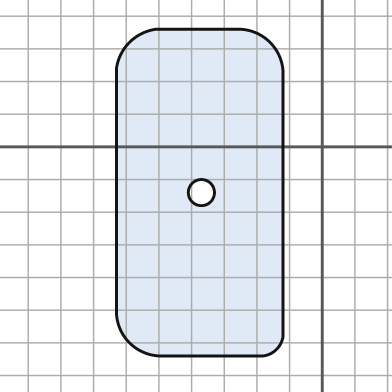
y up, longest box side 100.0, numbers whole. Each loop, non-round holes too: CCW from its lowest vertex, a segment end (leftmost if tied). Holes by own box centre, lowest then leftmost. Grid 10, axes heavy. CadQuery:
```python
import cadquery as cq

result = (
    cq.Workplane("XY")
    .moveTo(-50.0, -64.0)
    .lineTo(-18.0, -64.0)
    .threePointArc((-14.0, -62.0), (-12.0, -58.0))
    .lineTo(-12.0, 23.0)
    .threePointArc((-16.0, 32.0), (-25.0, 36.0))
    .lineTo(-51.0, 36.0)
    .threePointArc((-59.0, 32.0), (-63.0, 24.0))
    .lineTo(-63.0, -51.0)
    .threePointArc((-59.0, -60.0), (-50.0, -64.0))
    .close()
    .moveTo(-37.0, -14.0)
    .circle(4.0)
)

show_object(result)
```